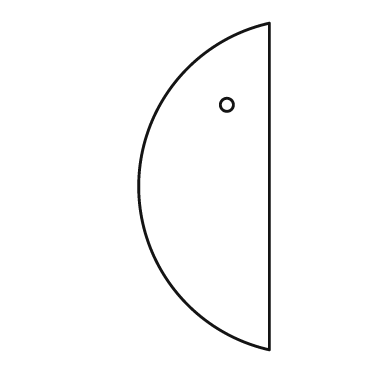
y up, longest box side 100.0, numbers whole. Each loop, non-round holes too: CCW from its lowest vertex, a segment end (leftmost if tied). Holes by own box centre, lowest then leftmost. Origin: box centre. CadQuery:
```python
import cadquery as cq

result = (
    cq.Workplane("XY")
    .moveTo(20.0, -50.0)
    .lineTo(20.0, 50.0)
    .threePointArc((-20.0, 0.0), (20.0, -50.0))
    .close()
    .moveTo(7.0, 25.0)
    .circle(2.0)
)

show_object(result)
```